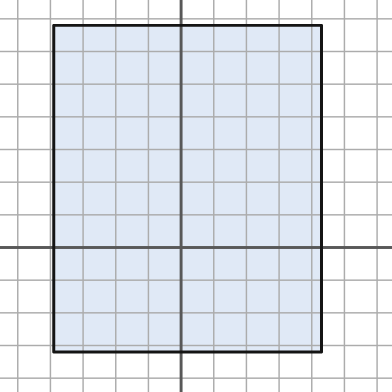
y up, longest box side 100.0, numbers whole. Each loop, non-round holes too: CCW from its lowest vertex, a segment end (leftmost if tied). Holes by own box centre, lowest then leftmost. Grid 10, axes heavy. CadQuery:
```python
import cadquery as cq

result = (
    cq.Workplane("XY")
    .moveTo(-39.0, -32.0)
    .lineTo(43.0, -32.0)
    .lineTo(43.0, 68.0)
    .lineTo(-39.0, 68.0)
    .close()
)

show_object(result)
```